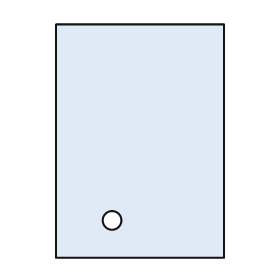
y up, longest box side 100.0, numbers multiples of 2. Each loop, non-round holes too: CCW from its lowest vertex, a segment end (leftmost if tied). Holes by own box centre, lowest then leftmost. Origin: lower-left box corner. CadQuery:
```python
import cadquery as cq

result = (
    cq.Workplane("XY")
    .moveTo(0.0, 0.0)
    .lineTo(72.0, 0.0)
    .lineTo(72.0, 100.0)
    .lineTo(0.0, 100.0)
    .close()
    .moveTo(24.0, 16.0)
    .circle(4.0)
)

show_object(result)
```